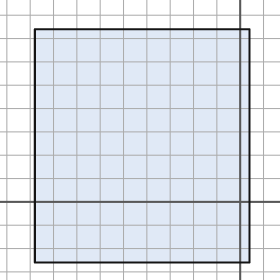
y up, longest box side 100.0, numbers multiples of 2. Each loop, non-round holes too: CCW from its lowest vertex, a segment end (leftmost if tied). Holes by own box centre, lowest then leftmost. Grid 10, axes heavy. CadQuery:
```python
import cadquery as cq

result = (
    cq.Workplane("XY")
    .moveTo(-88.0, -26.0)
    .lineTo(4.0, -26.0)
    .lineTo(4.0, 74.0)
    .lineTo(-88.0, 74.0)
    .close()
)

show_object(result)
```